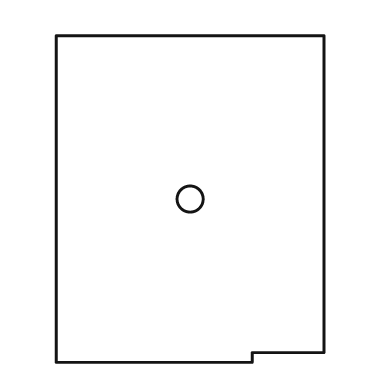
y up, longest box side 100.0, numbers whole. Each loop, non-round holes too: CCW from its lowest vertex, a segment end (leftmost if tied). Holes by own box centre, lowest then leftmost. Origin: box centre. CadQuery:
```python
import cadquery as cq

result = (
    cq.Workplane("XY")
    .moveTo(-41.0, -50.0)
    .lineTo(19.0, -50.0)
    .lineTo(19.0, -47.0)
    .lineTo(41.0, -47.0)
    .lineTo(41.0, 50.0)
    .lineTo(-41.0, 50.0)
    .close()
    .moveTo(0.0, 0.0)
    .circle(4.0)
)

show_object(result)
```